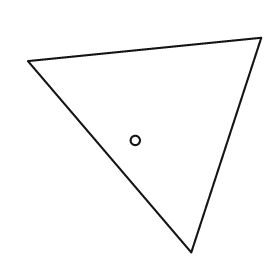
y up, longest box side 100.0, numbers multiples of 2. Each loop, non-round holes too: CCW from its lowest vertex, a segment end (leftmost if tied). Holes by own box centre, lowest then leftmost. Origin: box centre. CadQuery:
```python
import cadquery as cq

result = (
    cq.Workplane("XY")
    .moveTo(20.0, -46.0)
    .lineTo(50.0, 46.0)
    .lineTo(-50.0, 36.0)
    .close()
    .moveTo(-4.0, 2.0)
    .circle(2.0)
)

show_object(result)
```